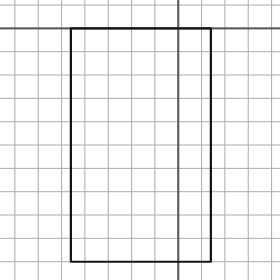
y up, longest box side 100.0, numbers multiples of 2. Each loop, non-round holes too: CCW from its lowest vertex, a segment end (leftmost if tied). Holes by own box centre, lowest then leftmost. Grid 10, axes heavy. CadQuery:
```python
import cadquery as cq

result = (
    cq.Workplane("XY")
    .moveTo(-46.0, -100.0)
    .lineTo(14.0, -100.0)
    .lineTo(14.0, 0.0)
    .lineTo(-46.0, 0.0)
    .close()
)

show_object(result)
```